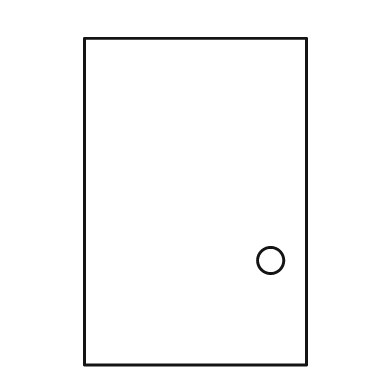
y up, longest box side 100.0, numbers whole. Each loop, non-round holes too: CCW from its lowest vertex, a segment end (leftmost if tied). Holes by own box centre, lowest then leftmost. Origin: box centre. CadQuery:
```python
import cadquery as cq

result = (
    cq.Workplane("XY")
    .moveTo(-34.0, -50.0)
    .lineTo(34.0, -50.0)
    .lineTo(34.0, 50.0)
    .lineTo(-34.0, 50.0)
    .close()
    .moveTo(23.0, -18.0)
    .circle(4.0)
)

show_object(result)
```